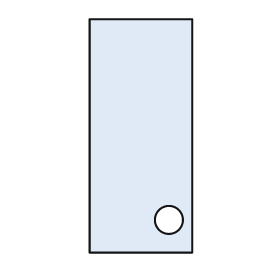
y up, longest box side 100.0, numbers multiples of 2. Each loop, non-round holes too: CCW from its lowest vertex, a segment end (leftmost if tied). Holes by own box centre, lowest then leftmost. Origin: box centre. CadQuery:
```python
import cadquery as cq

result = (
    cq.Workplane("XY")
    .moveTo(-22.0, -50.0)
    .lineTo(22.0, -50.0)
    .lineTo(22.0, 50.0)
    .lineTo(-22.0, 50.0)
    .close()
    .moveTo(12.0, -36.0)
    .circle(6.0)
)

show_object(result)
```